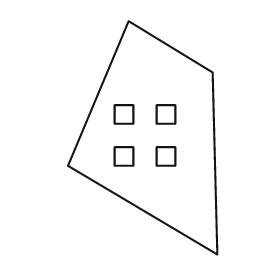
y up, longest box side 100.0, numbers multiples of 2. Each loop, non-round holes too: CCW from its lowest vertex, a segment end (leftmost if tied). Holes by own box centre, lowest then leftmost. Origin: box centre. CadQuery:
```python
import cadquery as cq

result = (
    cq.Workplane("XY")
    .moveTo(32.0, -50.0)
    .lineTo(30.0, 28.0)
    .lineTo(-6.0, 50.0)
    .lineTo(-32.0, -12.0)
    .close()
    .moveTo(-12.0, -12.0)
    .lineTo(-4.0, -12.0)
    .lineTo(-4.0, -4.0)
    .lineTo(-12.0, -4.0)
    .close()
    .moveTo(6.0, -12.0)
    .lineTo(14.0, -12.0)
    .lineTo(14.0, -4.0)
    .lineTo(6.0, -4.0)
    .close()
    .moveTo(-12.0, 6.0)
    .lineTo(-4.0, 6.0)
    .lineTo(-4.0, 14.0)
    .lineTo(-12.0, 14.0)
    .close()
    .moveTo(6.0, 6.0)
    .lineTo(14.0, 6.0)
    .lineTo(14.0, 14.0)
    .lineTo(6.0, 14.0)
    .close()
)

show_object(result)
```